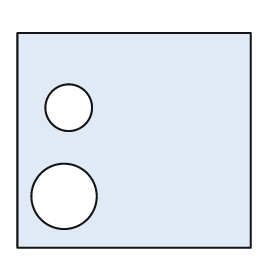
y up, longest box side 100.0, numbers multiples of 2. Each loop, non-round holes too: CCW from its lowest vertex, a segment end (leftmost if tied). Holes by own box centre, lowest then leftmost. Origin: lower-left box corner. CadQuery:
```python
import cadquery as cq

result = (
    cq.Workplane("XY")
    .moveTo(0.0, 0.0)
    .lineTo(100.0, 0.0)
    .lineTo(100.0, 92.0)
    .lineTo(0.0, 92.0)
    .close()
    .moveTo(20.0, 22.0)
    .circle(14.0)
    .moveTo(22.0, 60.0)
    .circle(10.0)
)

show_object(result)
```